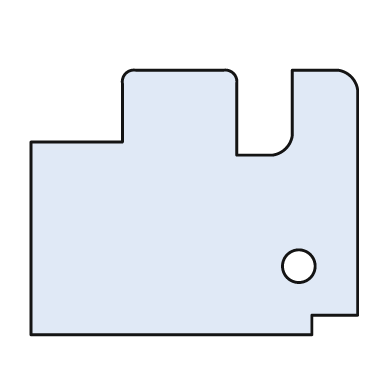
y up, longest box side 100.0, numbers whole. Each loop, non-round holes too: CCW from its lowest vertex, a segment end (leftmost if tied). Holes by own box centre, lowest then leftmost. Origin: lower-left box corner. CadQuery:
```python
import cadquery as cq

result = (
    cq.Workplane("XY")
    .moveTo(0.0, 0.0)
    .lineTo(86.0, 0.0)
    .lineTo(86.0, 6.0)
    .lineTo(100.0, 6.0)
    .lineTo(100.0, 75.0)
    .threePointArc((98.0, 79.0), (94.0, 81.0))
    .lineTo(80.0, 81.0)
    .lineTo(80.0, 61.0)
    .threePointArc((78.0, 57.0), (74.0, 55.0))
    .lineTo(63.0, 55.0)
    .lineTo(63.0, 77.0)
    .threePointArc((62.0, 80.0), (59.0, 81.0))
    .lineTo(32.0, 81.0)
    .threePointArc((29.0, 80.0), (28.0, 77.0))
    .lineTo(28.0, 59.0)
    .lineTo(0.0, 59.0)
    .close()
    .moveTo(82.0, 21.0)
    .circle(5.0)
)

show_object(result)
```